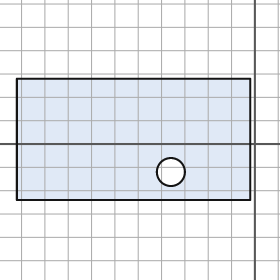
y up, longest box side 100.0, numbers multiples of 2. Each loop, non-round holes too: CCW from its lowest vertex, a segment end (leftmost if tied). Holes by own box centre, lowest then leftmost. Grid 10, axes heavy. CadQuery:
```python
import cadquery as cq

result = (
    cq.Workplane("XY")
    .moveTo(-102.0, -24.0)
    .lineTo(-2.0, -24.0)
    .lineTo(-2.0, 28.0)
    .lineTo(-102.0, 28.0)
    .close()
    .moveTo(-36.0, -12.0)
    .circle(6.0)
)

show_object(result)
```